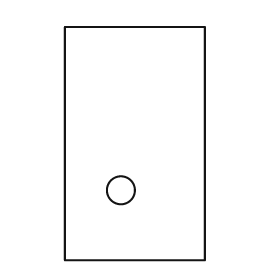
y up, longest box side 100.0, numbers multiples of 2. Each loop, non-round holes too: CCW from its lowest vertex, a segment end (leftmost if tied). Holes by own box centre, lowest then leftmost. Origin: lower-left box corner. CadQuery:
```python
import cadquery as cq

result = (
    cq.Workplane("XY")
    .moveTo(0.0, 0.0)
    .lineTo(60.0, 0.0)
    .lineTo(60.0, 100.0)
    .lineTo(0.0, 100.0)
    .close()
    .moveTo(24.0, 30.0)
    .circle(6.0)
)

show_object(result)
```